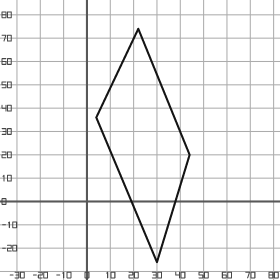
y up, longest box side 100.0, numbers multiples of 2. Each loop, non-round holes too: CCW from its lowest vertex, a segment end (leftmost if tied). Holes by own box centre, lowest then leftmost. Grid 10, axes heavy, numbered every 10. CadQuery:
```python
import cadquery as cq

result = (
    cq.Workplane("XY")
    .moveTo(30.0, -26.0)
    .lineTo(44.0, 20.0)
    .lineTo(22.0, 74.0)
    .lineTo(4.0, 36.0)
    .close()
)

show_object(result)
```